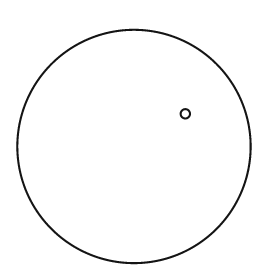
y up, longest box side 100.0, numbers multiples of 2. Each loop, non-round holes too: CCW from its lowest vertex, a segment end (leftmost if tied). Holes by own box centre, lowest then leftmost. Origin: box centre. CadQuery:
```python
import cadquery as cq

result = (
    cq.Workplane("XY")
    .moveTo(0.0, 0.0)
    .circle(50.0)
    .moveTo(22.0, 14.0)
    .circle(2.0)
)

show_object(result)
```